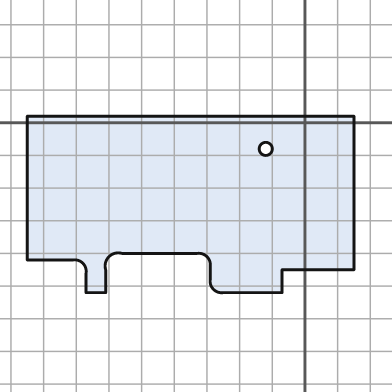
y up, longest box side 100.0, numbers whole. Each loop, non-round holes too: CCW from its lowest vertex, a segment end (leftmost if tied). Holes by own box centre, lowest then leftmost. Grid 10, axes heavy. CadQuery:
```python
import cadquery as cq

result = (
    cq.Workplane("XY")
    .moveTo(-67.0, -52.0)
    .lineTo(-61.0, -52.0)
    .lineTo(-61.0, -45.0)
    .threePointArc((-60.0, -41.0), (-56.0, -40.0))
    .lineTo(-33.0, -40.0)
    .threePointArc((-30.0, -41.0), (-29.0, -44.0))
    .lineTo(-29.0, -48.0)
    .threePointArc((-28.0, -51.0), (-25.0, -52.0))
    .lineTo(-7.0, -52.0)
    .lineTo(-7.0, -45.0)
    .lineTo(15.0, -45.0)
    .lineTo(15.0, 2.0)
    .lineTo(-85.0, 2.0)
    .lineTo(-85.0, -42.0)
    .lineTo(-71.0, -42.0)
    .threePointArc((-68.0, -43.0), (-67.0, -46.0))
    .close()
    .moveTo(-12.0, -8.0)
    .circle(2.0)
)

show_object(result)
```